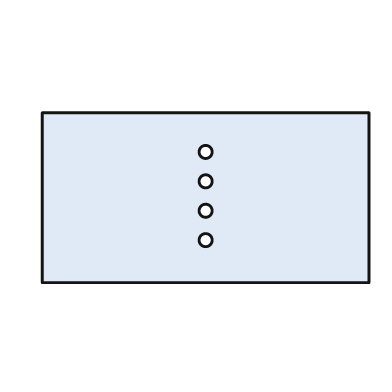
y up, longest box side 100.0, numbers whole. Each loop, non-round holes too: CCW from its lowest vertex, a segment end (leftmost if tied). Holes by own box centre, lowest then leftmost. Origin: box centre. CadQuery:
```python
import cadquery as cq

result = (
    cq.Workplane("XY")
    .moveTo(-50.0, -26.0)
    .lineTo(50.0, -26.0)
    .lineTo(50.0, 26.0)
    .lineTo(-50.0, 26.0)
    .close()
    .moveTo(0.0, -13.0)
    .circle(2.0)
    .moveTo(0.0, -4.0)
    .circle(2.0)
    .moveTo(0.0, 5.0)
    .circle(2.0)
    .moveTo(0.0, 14.0)
    .circle(2.0)
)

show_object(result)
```